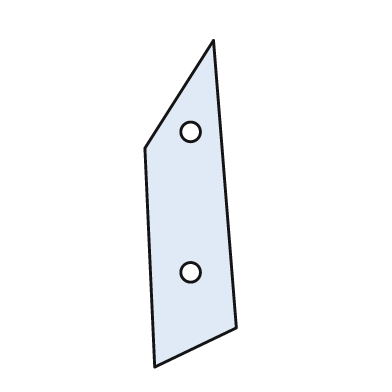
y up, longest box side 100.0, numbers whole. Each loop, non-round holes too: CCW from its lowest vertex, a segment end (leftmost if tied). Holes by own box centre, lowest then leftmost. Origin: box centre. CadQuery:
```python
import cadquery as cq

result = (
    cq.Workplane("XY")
    .moveTo(-11.0, -50.0)
    .lineTo(14.0, -38.0)
    .lineTo(7.0, 50.0)
    .lineTo(-14.0, 17.0)
    .close()
    .moveTo(0.0, -21.0)
    .circle(3.0)
    .moveTo(0.0, 22.0)
    .circle(3.0)
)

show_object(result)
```